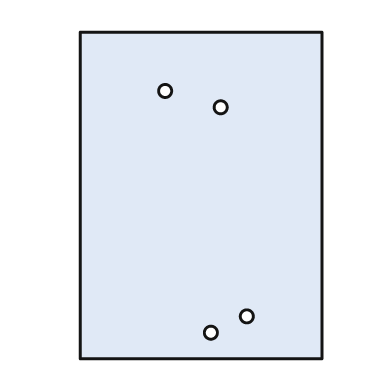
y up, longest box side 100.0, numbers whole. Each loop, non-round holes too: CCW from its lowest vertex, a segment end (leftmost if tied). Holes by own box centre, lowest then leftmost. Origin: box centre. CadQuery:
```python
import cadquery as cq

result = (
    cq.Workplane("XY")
    .moveTo(-37.0, -50.0)
    .lineTo(37.0, -50.0)
    .lineTo(37.0, 50.0)
    .lineTo(-37.0, 50.0)
    .close()
    .moveTo(3.0, -42.0)
    .circle(2.0)
    .moveTo(14.0, -37.0)
    .circle(2.0)
    .moveTo(6.0, 27.0)
    .circle(2.0)
    .moveTo(-11.0, 32.0)
    .circle(2.0)
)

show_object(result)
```